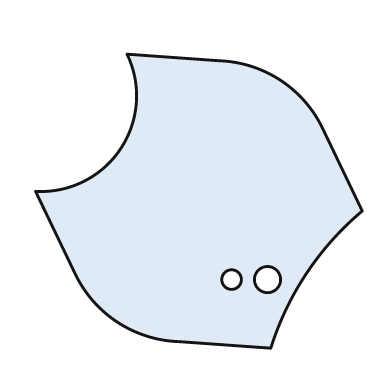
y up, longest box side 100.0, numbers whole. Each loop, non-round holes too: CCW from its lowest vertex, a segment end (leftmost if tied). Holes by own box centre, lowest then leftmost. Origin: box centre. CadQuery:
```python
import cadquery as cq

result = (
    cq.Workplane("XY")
    .moveTo(22.0, -45.0)
    .threePointArc((33.0, -22.0), (50.0, -3.0))
    .lineTo(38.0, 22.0)
    .threePointArc((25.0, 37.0), (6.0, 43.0))
    .lineTo(-22.0, 45.0)
    .threePointArc((-24.0, 16.0), (-50.0, 3.0))
    .lineTo(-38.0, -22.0)
    .threePointArc((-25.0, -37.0), (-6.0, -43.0))
    .close()
    .moveTo(10.0, -24.0)
    .circle(3.0)
    .moveTo(21.0, -24.0)
    .circle(4.0)
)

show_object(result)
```